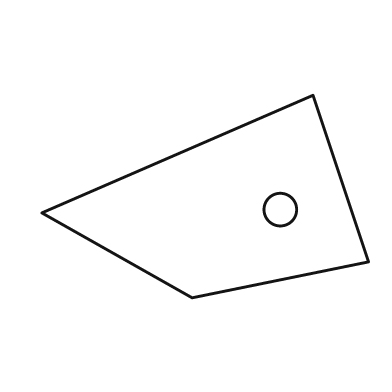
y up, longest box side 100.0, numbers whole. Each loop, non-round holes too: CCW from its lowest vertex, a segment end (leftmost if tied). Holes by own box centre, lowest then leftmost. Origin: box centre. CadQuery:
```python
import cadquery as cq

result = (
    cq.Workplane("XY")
    .moveTo(-4.0, -31.0)
    .lineTo(50.0, -20.0)
    .lineTo(33.0, 31.0)
    .lineTo(-50.0, -5.0)
    .close()
    .moveTo(23.0, -4.0)
    .circle(5.0)
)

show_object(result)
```